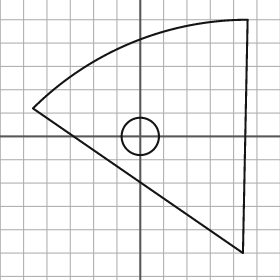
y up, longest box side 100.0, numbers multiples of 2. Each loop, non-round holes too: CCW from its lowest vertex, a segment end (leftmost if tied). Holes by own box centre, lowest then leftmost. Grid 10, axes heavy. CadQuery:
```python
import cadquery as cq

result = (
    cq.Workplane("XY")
    .moveTo(44.0, -50.0)
    .lineTo(46.0, 50.0)
    .threePointArc((-4.0, 40.0), (-46.0, 12.0))
    .close()
    .moveTo(0.0, 0.0)
    .circle(8.0)
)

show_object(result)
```